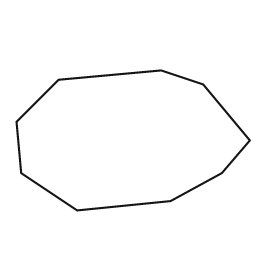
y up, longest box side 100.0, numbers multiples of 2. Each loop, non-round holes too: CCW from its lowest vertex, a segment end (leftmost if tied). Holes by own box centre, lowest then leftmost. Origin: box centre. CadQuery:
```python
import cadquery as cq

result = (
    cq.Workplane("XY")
    .moveTo(-24.0, -30.0)
    .lineTo(16.0, -26.0)
    .lineTo(38.0, -14.0)
    .lineTo(50.0, 0.0)
    .lineTo(30.0, 24.0)
    .lineTo(12.0, 30.0)
    .lineTo(-32.0, 26.0)
    .lineTo(-50.0, 8.0)
    .lineTo(-48.0, -14.0)
    .close()
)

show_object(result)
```